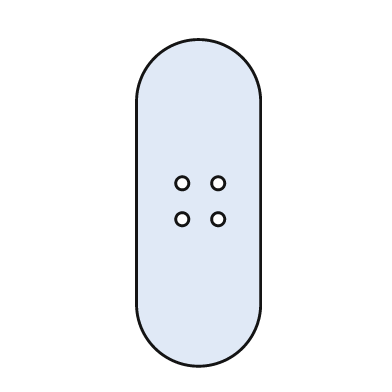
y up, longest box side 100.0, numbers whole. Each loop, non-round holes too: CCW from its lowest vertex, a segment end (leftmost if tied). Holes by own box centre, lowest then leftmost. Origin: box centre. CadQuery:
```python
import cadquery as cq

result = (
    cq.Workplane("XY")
    .moveTo(-19.0, -31.0)
    .threePointArc((0.0, -50.0), (19.0, -31.0))
    .lineTo(19.0, 31.0)
    .threePointArc((0.0, 50.0), (-19.0, 31.0))
    .close()
    .moveTo(-5.0, -5.0)
    .circle(2.0)
    .moveTo(6.0, -5.0)
    .circle(2.0)
    .moveTo(-5.0, 6.0)
    .circle(2.0)
    .moveTo(6.0, 6.0)
    .circle(2.0)
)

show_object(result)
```